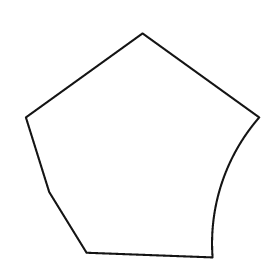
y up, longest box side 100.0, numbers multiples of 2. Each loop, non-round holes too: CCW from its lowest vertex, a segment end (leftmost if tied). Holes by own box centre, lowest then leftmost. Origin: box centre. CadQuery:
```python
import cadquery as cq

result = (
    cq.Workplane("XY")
    .moveTo(30.0, -48.0)
    .threePointArc((34.0, -16.0), (50.0, 12.0))
    .lineTo(0.0, 48.0)
    .lineTo(-50.0, 12.0)
    .lineTo(-40.0, -20.0)
    .lineTo(-24.0, -46.0)
    .close()
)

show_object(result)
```